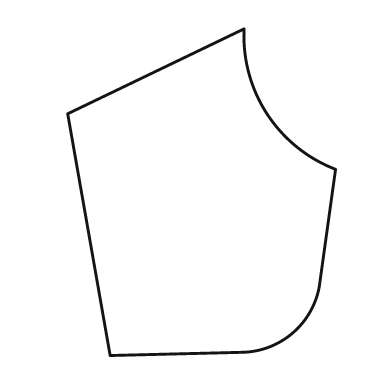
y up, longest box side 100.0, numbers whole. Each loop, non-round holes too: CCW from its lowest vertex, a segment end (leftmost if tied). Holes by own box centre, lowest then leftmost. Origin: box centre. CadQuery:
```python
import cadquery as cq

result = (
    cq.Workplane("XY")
    .moveTo(-28.0, -50.0)
    .lineTo(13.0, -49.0)
    .threePointArc((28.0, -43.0), (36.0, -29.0))
    .lineTo(41.0, 7.0)
    .threePointArc((20.0, 24.0), (13.0, 50.0))
    .lineTo(-41.0, 24.0)
    .close()
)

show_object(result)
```